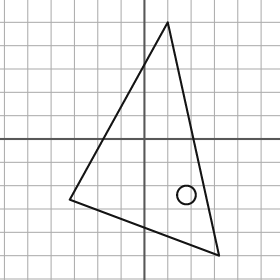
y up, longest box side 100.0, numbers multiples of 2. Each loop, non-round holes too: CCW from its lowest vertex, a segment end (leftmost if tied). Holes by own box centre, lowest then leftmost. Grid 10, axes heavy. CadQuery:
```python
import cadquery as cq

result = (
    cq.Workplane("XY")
    .moveTo(32.0, -50.0)
    .lineTo(10.0, 50.0)
    .lineTo(-32.0, -26.0)
    .close()
    .moveTo(18.0, -24.0)
    .circle(4.0)
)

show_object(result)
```